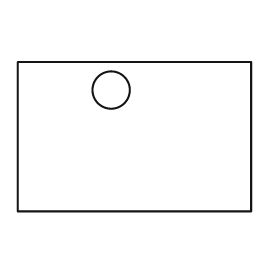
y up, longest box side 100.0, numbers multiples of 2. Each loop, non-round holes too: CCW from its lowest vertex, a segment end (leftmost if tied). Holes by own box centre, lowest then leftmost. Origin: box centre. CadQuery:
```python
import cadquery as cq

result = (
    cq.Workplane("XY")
    .moveTo(-50.0, -32.0)
    .lineTo(50.0, -32.0)
    .lineTo(50.0, 32.0)
    .lineTo(-50.0, 32.0)
    .close()
    .moveTo(-10.0, 20.0)
    .circle(8.0)
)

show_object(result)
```